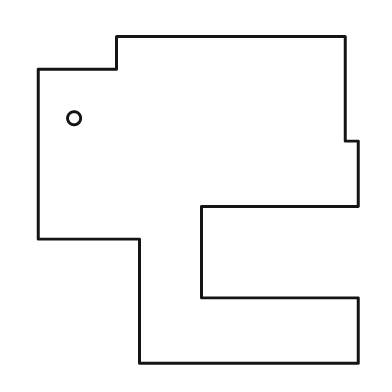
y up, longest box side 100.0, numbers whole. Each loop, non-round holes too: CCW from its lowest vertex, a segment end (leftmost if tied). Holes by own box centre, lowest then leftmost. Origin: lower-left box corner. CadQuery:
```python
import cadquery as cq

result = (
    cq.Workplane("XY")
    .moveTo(31.0, 0.0)
    .lineTo(98.0, 0.0)
    .lineTo(98.0, 20.0)
    .lineTo(50.0, 20.0)
    .lineTo(50.0, 48.0)
    .lineTo(98.0, 48.0)
    .lineTo(98.0, 68.0)
    .lineTo(94.0, 68.0)
    .lineTo(94.0, 100.0)
    .lineTo(24.0, 100.0)
    .lineTo(24.0, 90.0)
    .lineTo(0.0, 90.0)
    .lineTo(0.0, 38.0)
    .lineTo(31.0, 38.0)
    .close()
    .moveTo(11.0, 75.0)
    .circle(2.0)
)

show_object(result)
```